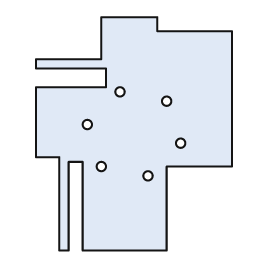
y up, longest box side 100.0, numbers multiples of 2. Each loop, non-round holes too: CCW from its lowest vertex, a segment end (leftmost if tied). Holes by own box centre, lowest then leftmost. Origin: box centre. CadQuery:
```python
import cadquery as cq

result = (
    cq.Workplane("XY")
    .moveTo(-32.0, -50.0)
    .lineTo(-28.0, -50.0)
    .lineTo(-28.0, -12.0)
    .lineTo(-22.0, -12.0)
    .lineTo(-22.0, -50.0)
    .lineTo(14.0, -50.0)
    .lineTo(14.0, -14.0)
    .lineTo(42.0, -14.0)
    .lineTo(42.0, 44.0)
    .lineTo(10.0, 44.0)
    .lineTo(10.0, 50.0)
    .lineTo(-14.0, 50.0)
    .lineTo(-14.0, 32.0)
    .lineTo(-42.0, 32.0)
    .lineTo(-42.0, 28.0)
    .lineTo(-12.0, 28.0)
    .lineTo(-12.0, 20.0)
    .lineTo(-42.0, 20.0)
    .lineTo(-42.0, -10.0)
    .lineTo(-32.0, -10.0)
    .close()
    .moveTo(6.0, -18.0)
    .circle(2.0)
    .moveTo(-14.0, -14.0)
    .circle(2.0)
    .moveTo(20.0, -4.0)
    .circle(2.0)
    .moveTo(-20.0, 4.0)
    .circle(2.0)
    .moveTo(14.0, 14.0)
    .circle(2.0)
    .moveTo(-6.0, 18.0)
    .circle(2.0)
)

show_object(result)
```